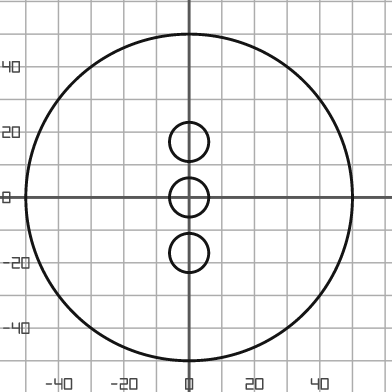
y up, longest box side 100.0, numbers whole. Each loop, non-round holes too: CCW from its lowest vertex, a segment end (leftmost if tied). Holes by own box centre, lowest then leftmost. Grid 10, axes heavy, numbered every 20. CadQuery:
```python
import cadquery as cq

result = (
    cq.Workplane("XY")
    .moveTo(0.0, 0.0)
    .circle(50.0)
    .moveTo(0.0, -17.0)
    .circle(6.0)
    .moveTo(0.0, 0.0)
    .circle(6.0)
    .moveTo(0.0, 17.0)
    .circle(6.0)
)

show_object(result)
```